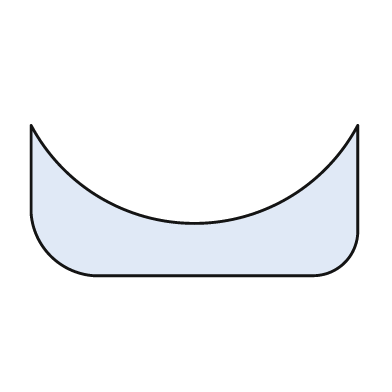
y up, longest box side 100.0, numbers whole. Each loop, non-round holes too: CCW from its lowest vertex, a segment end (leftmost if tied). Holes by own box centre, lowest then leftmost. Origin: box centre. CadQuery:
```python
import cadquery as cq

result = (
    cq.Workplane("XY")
    .moveTo(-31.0, -23.0)
    .lineTo(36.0, -23.0)
    .threePointArc((46.0, -19.0), (50.0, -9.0))
    .lineTo(50.0, 23.0)
    .threePointArc((0.0, -7.0), (-50.0, 23.0))
    .lineTo(-50.0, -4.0)
    .threePointArc((-44.0, -17.0), (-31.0, -23.0))
    .close()
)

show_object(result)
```